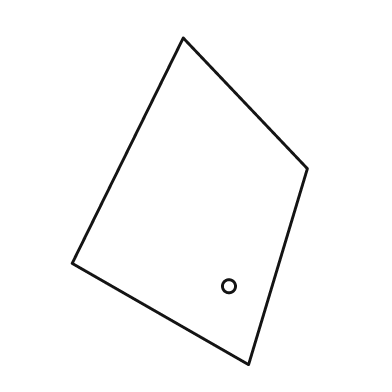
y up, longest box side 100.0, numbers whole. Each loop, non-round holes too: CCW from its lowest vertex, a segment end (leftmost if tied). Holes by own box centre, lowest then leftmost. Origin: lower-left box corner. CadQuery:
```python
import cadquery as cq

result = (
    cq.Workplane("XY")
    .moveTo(54.0, 0.0)
    .lineTo(72.0, 60.0)
    .lineTo(34.0, 100.0)
    .lineTo(0.0, 31.0)
    .close()
    .moveTo(48.0, 24.0)
    .circle(2.0)
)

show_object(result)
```